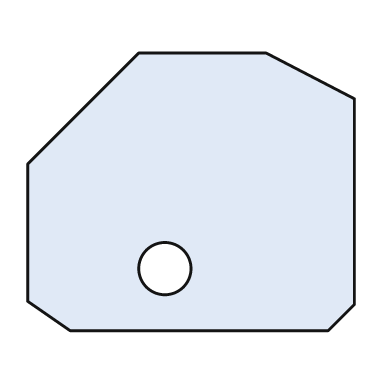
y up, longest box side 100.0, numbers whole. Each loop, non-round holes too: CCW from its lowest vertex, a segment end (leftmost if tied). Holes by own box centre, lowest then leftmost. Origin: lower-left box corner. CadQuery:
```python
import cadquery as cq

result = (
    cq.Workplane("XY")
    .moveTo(13.0, 0.0)
    .lineTo(92.0, 0.0)
    .lineTo(100.0, 8.0)
    .lineTo(100.0, 71.0)
    .lineTo(73.0, 85.0)
    .lineTo(34.0, 85.0)
    .lineTo(0.0, 51.0)
    .lineTo(0.0, 9.0)
    .close()
    .moveTo(42.0, 19.0)
    .circle(8.0)
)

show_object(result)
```